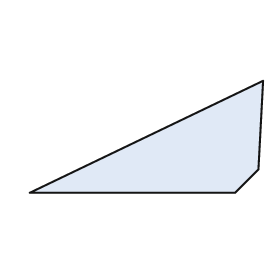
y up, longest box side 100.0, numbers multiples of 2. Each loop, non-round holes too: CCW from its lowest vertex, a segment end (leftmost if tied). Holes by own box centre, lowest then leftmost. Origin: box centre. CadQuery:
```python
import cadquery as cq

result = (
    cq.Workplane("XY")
    .moveTo(-50.0, -24.0)
    .lineTo(38.0, -24.0)
    .lineTo(48.0, -14.0)
    .lineTo(50.0, 24.0)
    .close()
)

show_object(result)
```